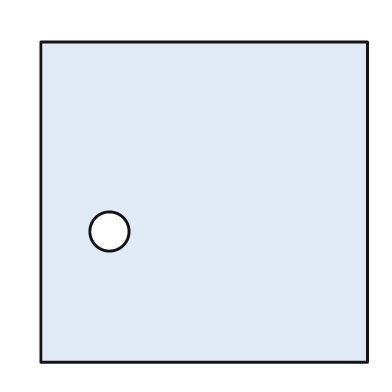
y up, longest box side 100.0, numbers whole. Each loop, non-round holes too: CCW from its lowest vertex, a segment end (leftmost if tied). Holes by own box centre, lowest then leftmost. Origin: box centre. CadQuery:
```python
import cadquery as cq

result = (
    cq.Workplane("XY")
    .moveTo(-50.0, -49.0)
    .lineTo(50.0, -49.0)
    .lineTo(50.0, 49.0)
    .lineTo(-50.0, 49.0)
    .close()
    .moveTo(-29.0, -9.0)
    .circle(6.0)
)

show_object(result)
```